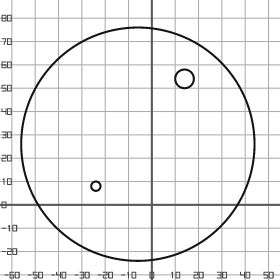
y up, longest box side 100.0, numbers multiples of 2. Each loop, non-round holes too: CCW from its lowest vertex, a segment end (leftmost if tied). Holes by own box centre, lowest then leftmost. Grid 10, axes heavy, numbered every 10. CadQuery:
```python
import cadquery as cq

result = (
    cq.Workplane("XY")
    .moveTo(-6.0, 26.0)
    .circle(50.0)
    .moveTo(-24.0, 8.0)
    .circle(2.0)
    .moveTo(14.0, 54.0)
    .circle(4.0)
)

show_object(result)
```